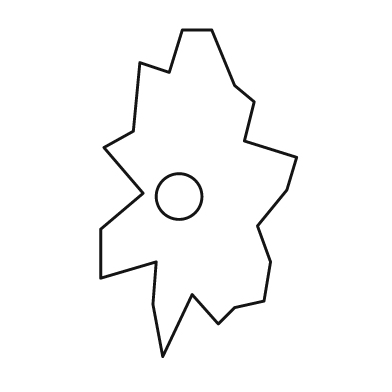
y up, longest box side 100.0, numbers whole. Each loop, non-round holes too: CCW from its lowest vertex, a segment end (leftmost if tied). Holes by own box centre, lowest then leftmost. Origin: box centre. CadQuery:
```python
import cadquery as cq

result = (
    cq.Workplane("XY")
    .moveTo(-11.0, -50.0)
    .lineTo(-2.0, -31.0)
    .lineTo(6.0, -40.0)
    .lineTo(11.0, -35.0)
    .lineTo(20.0, -33.0)
    .lineTo(22.0, -21.0)
    .lineTo(18.0, -10.0)
    .lineTo(27.0, 1.0)
    .lineTo(30.0, 11.0)
    .lineTo(14.0, 16.0)
    .lineTo(17.0, 28.0)
    .lineTo(11.0, 33.0)
    .lineTo(4.0, 50.0)
    .lineTo(-5.0, 50.0)
    .lineTo(-9.0, 37.0)
    .lineTo(-18.0, 40.0)
    .lineTo(-20.0, 19.0)
    .lineTo(-29.0, 14.0)
    .lineTo(-17.0, 0.0)
    .lineTo(-30.0, -11.0)
    .lineTo(-30.0, -26.0)
    .lineTo(-13.0, -21.0)
    .lineTo(-14.0, -34.0)
    .close()
    .moveTo(-6.0, -1.0)
    .circle(7.0)
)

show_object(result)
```